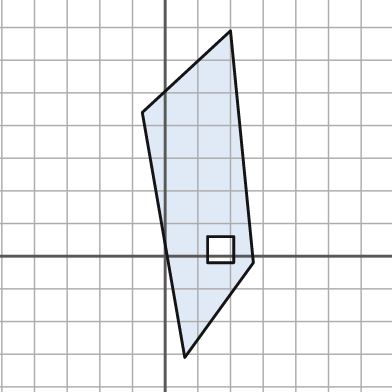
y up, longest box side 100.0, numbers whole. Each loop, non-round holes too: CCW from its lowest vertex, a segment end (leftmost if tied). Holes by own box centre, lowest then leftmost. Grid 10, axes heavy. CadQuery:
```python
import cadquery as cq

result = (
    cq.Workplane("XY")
    .moveTo(6.0, -31.0)
    .lineTo(27.0, -2.0)
    .lineTo(20.0, 69.0)
    .lineTo(-7.0, 44.0)
    .close()
    .moveTo(13.0, -2.0)
    .lineTo(21.0, -2.0)
    .lineTo(21.0, 6.0)
    .lineTo(13.0, 6.0)
    .close()
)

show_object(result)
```